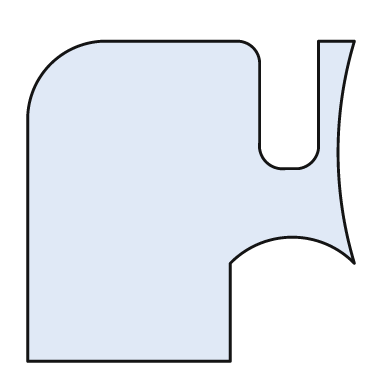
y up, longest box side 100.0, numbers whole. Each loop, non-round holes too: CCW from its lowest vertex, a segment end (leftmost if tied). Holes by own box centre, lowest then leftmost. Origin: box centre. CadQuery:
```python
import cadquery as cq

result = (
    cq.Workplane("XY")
    .moveTo(-50.0, -49.0)
    .lineTo(12.0, -49.0)
    .lineTo(12.0, -19.0)
    .threePointArc((31.0, -11.0), (50.0, -19.0))
    .threePointArc((45.0, 15.0), (50.0, 49.0))
    .lineTo(39.0, 49.0)
    .lineTo(39.0, 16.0)
    .threePointArc((37.0, 12.0), (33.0, 10.0))
    .lineTo(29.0, 10.0)
    .threePointArc((23.0, 12.0), (21.0, 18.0))
    .lineTo(21.0, 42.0)
    .threePointArc((19.0, 47.0), (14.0, 49.0))
    .lineTo(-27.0, 49.0)
    .threePointArc((-43.0, 42.0), (-50.0, 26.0))
    .close()
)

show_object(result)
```